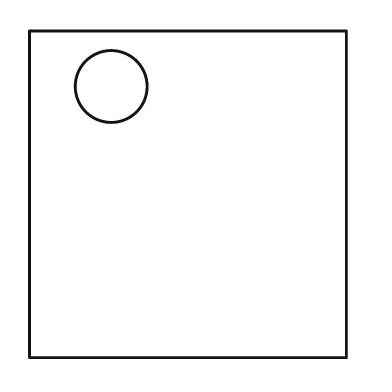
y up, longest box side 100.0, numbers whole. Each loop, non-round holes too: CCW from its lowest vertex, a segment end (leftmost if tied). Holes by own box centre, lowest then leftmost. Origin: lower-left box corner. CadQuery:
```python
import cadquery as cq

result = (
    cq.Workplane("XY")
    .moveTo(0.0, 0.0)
    .lineTo(97.0, 0.0)
    .lineTo(97.0, 100.0)
    .lineTo(0.0, 100.0)
    .close()
    .moveTo(25.0, 83.0)
    .circle(11.0)
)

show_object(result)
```